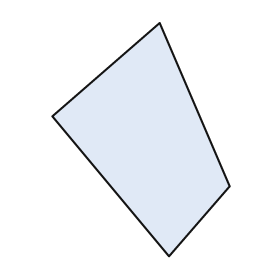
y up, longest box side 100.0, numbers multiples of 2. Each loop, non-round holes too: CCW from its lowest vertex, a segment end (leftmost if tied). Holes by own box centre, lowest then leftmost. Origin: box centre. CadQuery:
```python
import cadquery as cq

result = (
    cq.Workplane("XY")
    .moveTo(12.0, -50.0)
    .lineTo(38.0, -20.0)
    .lineTo(8.0, 50.0)
    .lineTo(-38.0, 10.0)
    .close()
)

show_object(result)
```